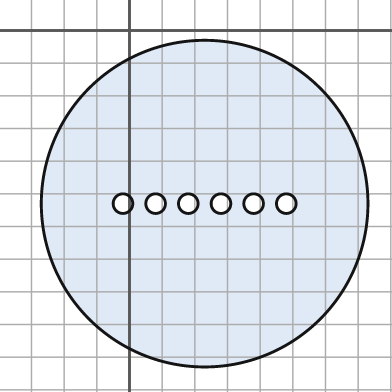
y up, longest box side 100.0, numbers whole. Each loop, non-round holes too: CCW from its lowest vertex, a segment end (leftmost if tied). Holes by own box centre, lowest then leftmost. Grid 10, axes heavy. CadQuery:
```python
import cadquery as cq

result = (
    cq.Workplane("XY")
    .moveTo(23.0, -53.0)
    .circle(50.0)
    .moveTo(-2.0, -53.0)
    .circle(3.0)
    .moveTo(8.0, -53.0)
    .circle(3.0)
    .moveTo(18.0, -53.0)
    .circle(3.0)
    .moveTo(28.0, -53.0)
    .circle(3.0)
    .moveTo(38.0, -53.0)
    .circle(3.0)
    .moveTo(48.0, -53.0)
    .circle(3.0)
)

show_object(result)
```